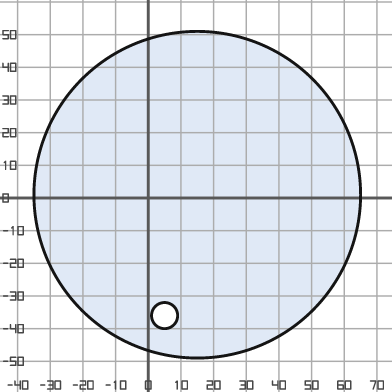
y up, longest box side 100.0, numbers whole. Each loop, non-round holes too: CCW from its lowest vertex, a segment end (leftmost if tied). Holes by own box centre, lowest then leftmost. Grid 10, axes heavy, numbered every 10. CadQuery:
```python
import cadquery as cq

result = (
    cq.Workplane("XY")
    .moveTo(15.0, 1.0)
    .circle(50.0)
    .moveTo(5.0, -36.0)
    .circle(4.0)
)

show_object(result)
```